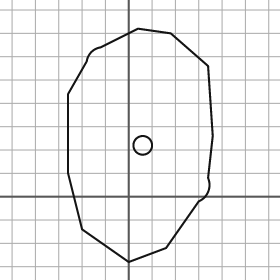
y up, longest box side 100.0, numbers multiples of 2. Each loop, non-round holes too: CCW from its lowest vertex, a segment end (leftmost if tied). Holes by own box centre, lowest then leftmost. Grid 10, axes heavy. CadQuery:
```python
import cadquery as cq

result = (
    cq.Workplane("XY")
    .moveTo(0.0, -28.0)
    .lineTo(16.0, -22.0)
    .lineTo(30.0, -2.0)
    .threePointArc((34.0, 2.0), (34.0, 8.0))
    .lineTo(36.0, 26.0)
    .lineTo(34.0, 56.0)
    .lineTo(18.0, 70.0)
    .lineTo(4.0, 72.0)
    .lineTo(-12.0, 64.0)
    .threePointArc((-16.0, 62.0), (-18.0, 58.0))
    .lineTo(-26.0, 44.0)
    .lineTo(-26.0, 10.0)
    .lineTo(-20.0, -14.0)
    .close()
    .moveTo(6.0, 22.0)
    .circle(4.0)
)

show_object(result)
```